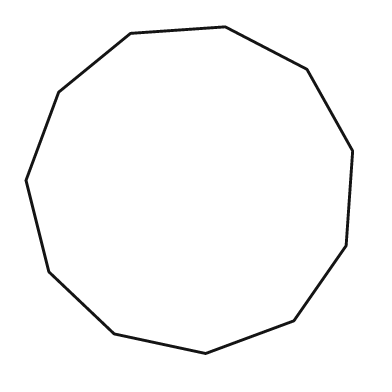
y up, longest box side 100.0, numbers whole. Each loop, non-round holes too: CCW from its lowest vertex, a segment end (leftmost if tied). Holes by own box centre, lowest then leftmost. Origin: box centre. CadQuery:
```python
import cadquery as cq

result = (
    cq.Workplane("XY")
    .moveTo(5.0, -50.0)
    .lineTo(32.0, -40.0)
    .lineTo(48.0, -17.0)
    .lineTo(50.0, 12.0)
    .lineTo(36.0, 37.0)
    .lineTo(11.0, 50.0)
    .lineTo(-18.0, 48.0)
    .lineTo(-40.0, 30.0)
    .lineTo(-50.0, 3.0)
    .lineTo(-43.0, -25.0)
    .lineTo(-23.0, -44.0)
    .close()
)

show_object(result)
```